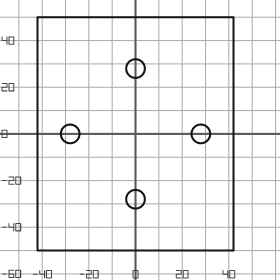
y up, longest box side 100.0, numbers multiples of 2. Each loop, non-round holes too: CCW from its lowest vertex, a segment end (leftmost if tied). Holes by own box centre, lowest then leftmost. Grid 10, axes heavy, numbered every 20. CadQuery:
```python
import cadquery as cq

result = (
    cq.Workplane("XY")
    .moveTo(-42.0, -50.0)
    .lineTo(42.0, -50.0)
    .lineTo(42.0, 50.0)
    .lineTo(-42.0, 50.0)
    .close()
    .moveTo(0.0, -28.0)
    .circle(4.0)
    .moveTo(-28.0, 0.0)
    .circle(4.0)
    .moveTo(28.0, 0.0)
    .circle(4.0)
    .moveTo(0.0, 28.0)
    .circle(4.0)
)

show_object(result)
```